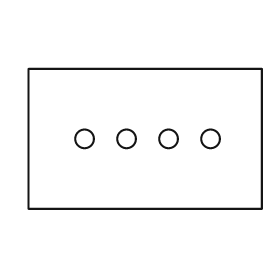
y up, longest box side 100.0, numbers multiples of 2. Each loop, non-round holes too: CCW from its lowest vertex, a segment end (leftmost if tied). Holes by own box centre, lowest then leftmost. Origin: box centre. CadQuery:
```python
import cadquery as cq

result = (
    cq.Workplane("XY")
    .moveTo(-50.0, -30.0)
    .lineTo(50.0, -30.0)
    .lineTo(50.0, 30.0)
    .lineTo(-50.0, 30.0)
    .close()
    .moveTo(-26.0, 0.0)
    .circle(4.0)
    .moveTo(-8.0, 0.0)
    .circle(4.0)
    .moveTo(10.0, 0.0)
    .circle(4.0)
    .moveTo(28.0, 0.0)
    .circle(4.0)
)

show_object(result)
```